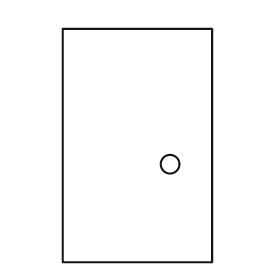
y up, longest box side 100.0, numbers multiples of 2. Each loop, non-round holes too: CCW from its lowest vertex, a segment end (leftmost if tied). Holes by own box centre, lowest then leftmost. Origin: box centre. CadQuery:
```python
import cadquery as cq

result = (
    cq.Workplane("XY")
    .moveTo(-32.0, -50.0)
    .lineTo(32.0, -50.0)
    .lineTo(32.0, 50.0)
    .lineTo(-32.0, 50.0)
    .close()
    .moveTo(14.0, -8.0)
    .circle(4.0)
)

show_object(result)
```